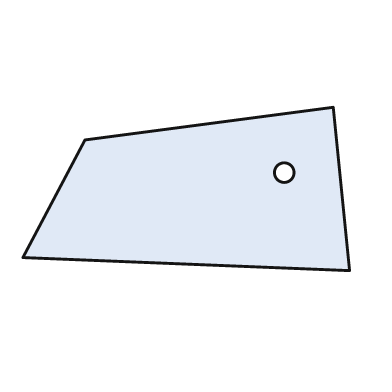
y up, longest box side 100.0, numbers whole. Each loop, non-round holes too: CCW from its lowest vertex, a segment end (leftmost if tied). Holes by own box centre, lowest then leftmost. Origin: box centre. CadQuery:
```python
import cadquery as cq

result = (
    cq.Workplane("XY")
    .moveTo(50.0, -25.0)
    .lineTo(45.0, 25.0)
    .lineTo(-31.0, 15.0)
    .lineTo(-50.0, -21.0)
    .close()
    .moveTo(30.0, 5.0)
    .circle(3.0)
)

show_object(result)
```